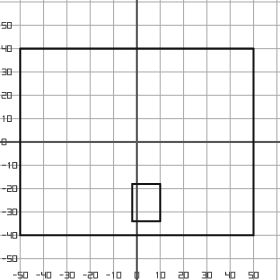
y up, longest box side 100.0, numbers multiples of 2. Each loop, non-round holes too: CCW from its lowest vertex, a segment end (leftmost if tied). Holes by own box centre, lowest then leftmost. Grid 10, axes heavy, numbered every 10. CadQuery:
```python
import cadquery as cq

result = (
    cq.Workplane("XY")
    .moveTo(-50.0, -40.0)
    .lineTo(50.0, -40.0)
    .lineTo(50.0, 40.0)
    .lineTo(-50.0, 40.0)
    .close()
    .moveTo(-2.0, -34.0)
    .lineTo(10.0, -34.0)
    .lineTo(10.0, -18.0)
    .lineTo(-2.0, -18.0)
    .close()
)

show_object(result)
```